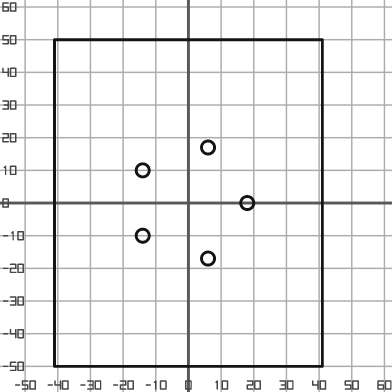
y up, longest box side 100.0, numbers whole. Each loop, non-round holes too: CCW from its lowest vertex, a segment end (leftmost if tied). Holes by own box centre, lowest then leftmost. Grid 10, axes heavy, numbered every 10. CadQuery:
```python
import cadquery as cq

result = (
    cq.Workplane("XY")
    .moveTo(-41.0, -50.0)
    .lineTo(41.0, -50.0)
    .lineTo(41.0, 50.0)
    .lineTo(-41.0, 50.0)
    .close()
    .moveTo(6.0, -17.0)
    .circle(2.0)
    .moveTo(-14.0, -10.0)
    .circle(2.0)
    .moveTo(18.0, 0.0)
    .circle(2.0)
    .moveTo(-14.0, 10.0)
    .circle(2.0)
    .moveTo(6.0, 17.0)
    .circle(2.0)
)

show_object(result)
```